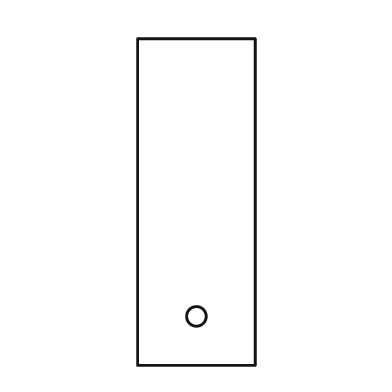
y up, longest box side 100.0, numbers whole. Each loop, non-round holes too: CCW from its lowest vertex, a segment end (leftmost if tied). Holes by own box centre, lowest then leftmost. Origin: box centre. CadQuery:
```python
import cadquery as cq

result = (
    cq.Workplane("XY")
    .moveTo(-18.0, -50.0)
    .lineTo(18.0, -50.0)
    .lineTo(18.0, 50.0)
    .lineTo(-18.0, 50.0)
    .close()
    .moveTo(0.0, -35.0)
    .circle(3.0)
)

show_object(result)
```